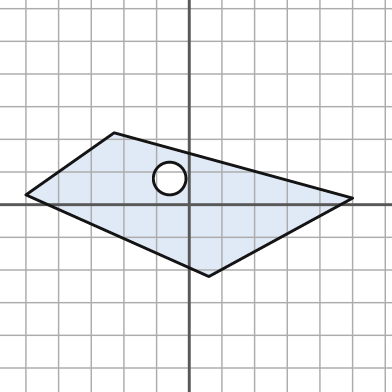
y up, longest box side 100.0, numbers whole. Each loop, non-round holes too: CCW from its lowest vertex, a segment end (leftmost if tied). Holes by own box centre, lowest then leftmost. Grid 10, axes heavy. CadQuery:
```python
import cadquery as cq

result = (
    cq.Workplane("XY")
    .moveTo(6.0, -22.0)
    .lineTo(50.0, 2.0)
    .lineTo(-23.0, 22.0)
    .lineTo(-50.0, 3.0)
    .close()
    .moveTo(-6.0, 8.0)
    .circle(5.0)
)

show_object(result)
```